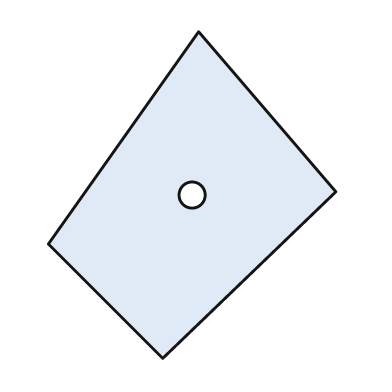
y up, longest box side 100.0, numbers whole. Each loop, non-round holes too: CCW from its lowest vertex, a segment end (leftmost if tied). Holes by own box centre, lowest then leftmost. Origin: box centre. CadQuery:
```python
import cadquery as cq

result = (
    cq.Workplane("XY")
    .moveTo(-9.0, -50.0)
    .lineTo(44.0, 1.0)
    .lineTo(2.0, 50.0)
    .lineTo(-44.0, -15.0)
    .close()
    .moveTo(0.0, 0.0)
    .circle(4.0)
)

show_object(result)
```